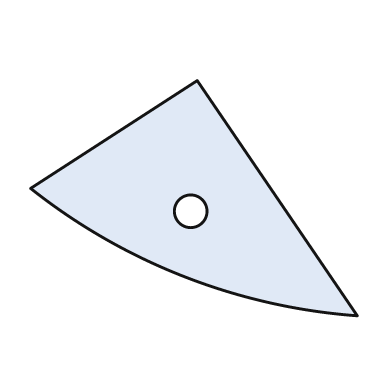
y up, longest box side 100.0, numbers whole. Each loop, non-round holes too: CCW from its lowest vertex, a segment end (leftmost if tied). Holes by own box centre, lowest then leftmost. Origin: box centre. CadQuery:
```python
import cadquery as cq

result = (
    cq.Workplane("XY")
    .moveTo(50.0, -36.0)
    .lineTo(1.0, 36.0)
    .lineTo(-50.0, 3.0)
    .threePointArc((-3.0, -24.0), (50.0, -36.0))
    .close()
    .moveTo(-1.0, -4.0)
    .circle(5.0)
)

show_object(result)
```